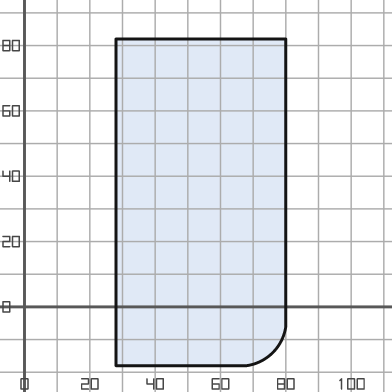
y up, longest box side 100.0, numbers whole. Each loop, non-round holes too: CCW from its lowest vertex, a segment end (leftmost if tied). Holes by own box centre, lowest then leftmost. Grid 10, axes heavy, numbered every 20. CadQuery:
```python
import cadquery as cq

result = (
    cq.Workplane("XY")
    .moveTo(28.0, -18.0)
    .lineTo(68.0, -18.0)
    .threePointArc((76.0, -14.0), (80.0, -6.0))
    .lineTo(80.0, 82.0)
    .lineTo(28.0, 82.0)
    .close()
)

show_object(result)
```